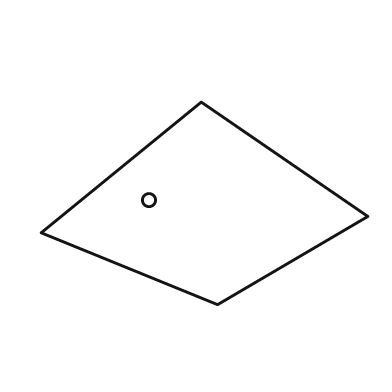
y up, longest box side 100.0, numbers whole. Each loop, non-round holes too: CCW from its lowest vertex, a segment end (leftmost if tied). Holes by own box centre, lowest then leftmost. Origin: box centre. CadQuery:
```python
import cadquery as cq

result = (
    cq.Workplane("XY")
    .moveTo(4.0, -31.0)
    .lineTo(50.0, -4.0)
    .lineTo(-1.0, 31.0)
    .lineTo(-50.0, -9.0)
    .close()
    .moveTo(-17.0, 1.0)
    .circle(2.0)
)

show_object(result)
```